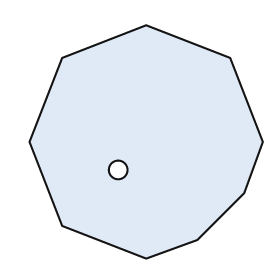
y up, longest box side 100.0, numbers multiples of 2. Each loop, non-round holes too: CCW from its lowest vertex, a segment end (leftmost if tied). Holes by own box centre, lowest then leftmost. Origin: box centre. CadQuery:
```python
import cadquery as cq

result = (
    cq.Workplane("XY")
    .moveTo(0.0, -50.0)
    .lineTo(22.0, -42.0)
    .lineTo(42.0, -22.0)
    .lineTo(50.0, 0.0)
    .lineTo(36.0, 36.0)
    .lineTo(0.0, 50.0)
    .lineTo(-36.0, 36.0)
    .lineTo(-50.0, 0.0)
    .lineTo(-36.0, -36.0)
    .close()
    .moveTo(-12.0, -12.0)
    .circle(4.0)
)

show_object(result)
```